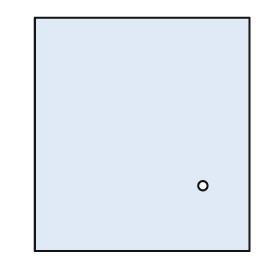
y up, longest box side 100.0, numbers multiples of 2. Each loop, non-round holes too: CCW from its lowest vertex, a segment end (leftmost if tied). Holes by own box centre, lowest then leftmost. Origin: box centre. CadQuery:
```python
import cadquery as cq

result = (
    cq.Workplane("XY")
    .moveTo(-46.0, -50.0)
    .lineTo(46.0, -50.0)
    .lineTo(46.0, 50.0)
    .lineTo(-46.0, 50.0)
    .close()
    .moveTo(26.0, -22.0)
    .circle(2.0)
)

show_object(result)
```